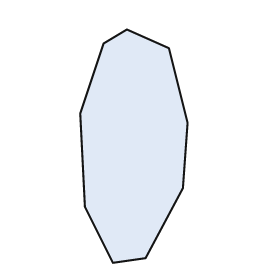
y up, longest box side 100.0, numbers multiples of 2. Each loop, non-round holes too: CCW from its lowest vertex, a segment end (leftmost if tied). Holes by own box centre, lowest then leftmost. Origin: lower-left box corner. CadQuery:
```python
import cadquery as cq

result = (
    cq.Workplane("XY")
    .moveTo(14.0, 0.0)
    .lineTo(28.0, 2.0)
    .lineTo(44.0, 32.0)
    .lineTo(46.0, 60.0)
    .lineTo(38.0, 92.0)
    .lineTo(20.0, 100.0)
    .lineTo(10.0, 94.0)
    .lineTo(0.0, 64.0)
    .lineTo(2.0, 24.0)
    .close()
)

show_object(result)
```